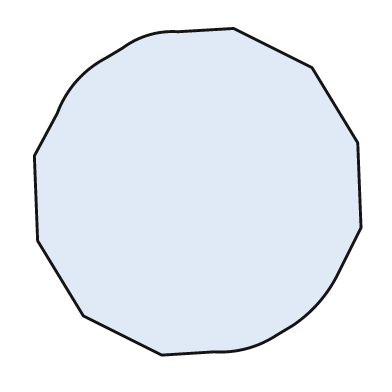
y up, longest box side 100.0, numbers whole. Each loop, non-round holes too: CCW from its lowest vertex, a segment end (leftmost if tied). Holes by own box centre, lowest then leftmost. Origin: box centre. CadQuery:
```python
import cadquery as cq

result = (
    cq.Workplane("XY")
    .moveTo(-11.0, -50.0)
    .lineTo(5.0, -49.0)
    .threePointArc((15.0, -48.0), (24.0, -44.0))
    .lineTo(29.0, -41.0)
    .threePointArc((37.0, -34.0), (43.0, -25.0))
    .lineTo(50.0, -11.0)
    .lineTo(49.0, 15.0)
    .lineTo(35.0, 38.0)
    .lineTo(11.0, 50.0)
    .lineTo(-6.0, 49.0)
    .threePointArc((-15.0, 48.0), (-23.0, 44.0))
    .lineTo(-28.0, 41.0)
    .threePointArc((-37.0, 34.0), (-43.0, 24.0))
    .lineTo(-50.0, 11.0)
    .lineTo(-49.0, -15.0)
    .lineTo(-35.0, -38.0)
    .close()
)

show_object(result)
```